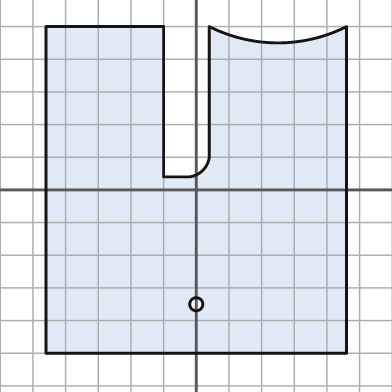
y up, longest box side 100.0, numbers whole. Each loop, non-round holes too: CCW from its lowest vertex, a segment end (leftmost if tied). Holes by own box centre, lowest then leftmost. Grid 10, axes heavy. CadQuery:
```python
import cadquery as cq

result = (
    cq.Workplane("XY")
    .moveTo(-46.0, -50.0)
    .lineTo(46.0, -50.0)
    .lineTo(46.0, 50.0)
    .threePointArc((25.0, 45.0), (4.0, 50.0))
    .lineTo(4.0, 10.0)
    .threePointArc((2.0, 6.0), (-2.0, 4.0))
    .lineTo(-10.0, 4.0)
    .lineTo(-10.0, 50.0)
    .lineTo(-46.0, 50.0)
    .close()
    .moveTo(0.0, -35.0)
    .circle(2.0)
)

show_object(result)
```